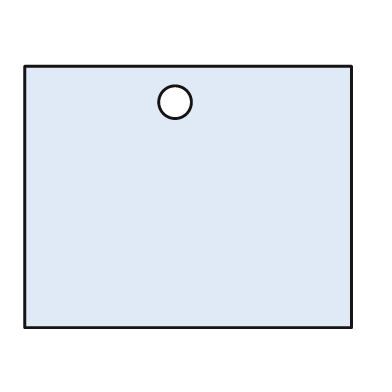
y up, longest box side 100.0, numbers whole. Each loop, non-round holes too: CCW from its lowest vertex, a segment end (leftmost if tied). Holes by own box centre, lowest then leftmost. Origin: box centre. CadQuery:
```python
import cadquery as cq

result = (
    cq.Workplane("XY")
    .moveTo(-50.0, -40.0)
    .lineTo(50.0, -40.0)
    .lineTo(50.0, 40.0)
    .lineTo(-50.0, 40.0)
    .close()
    .moveTo(-4.0, 29.0)
    .circle(5.0)
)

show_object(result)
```